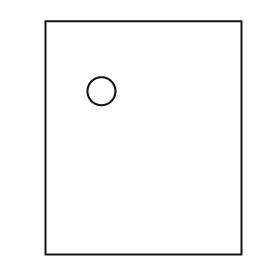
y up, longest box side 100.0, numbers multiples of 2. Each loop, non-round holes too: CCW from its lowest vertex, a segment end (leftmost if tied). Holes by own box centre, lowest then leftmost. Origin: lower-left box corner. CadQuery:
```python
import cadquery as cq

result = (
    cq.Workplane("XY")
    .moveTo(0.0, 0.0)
    .lineTo(84.0, 0.0)
    .lineTo(84.0, 100.0)
    .lineTo(0.0, 100.0)
    .close()
    .moveTo(24.0, 70.0)
    .circle(6.0)
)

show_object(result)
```